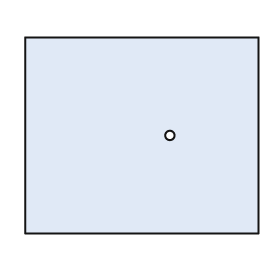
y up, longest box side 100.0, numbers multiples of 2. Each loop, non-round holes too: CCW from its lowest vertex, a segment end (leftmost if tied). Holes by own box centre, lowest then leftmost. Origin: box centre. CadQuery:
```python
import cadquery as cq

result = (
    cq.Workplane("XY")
    .moveTo(-50.0, -42.0)
    .lineTo(50.0, -42.0)
    .lineTo(50.0, 42.0)
    .lineTo(-50.0, 42.0)
    .close()
    .moveTo(12.0, 0.0)
    .circle(2.0)
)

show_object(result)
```